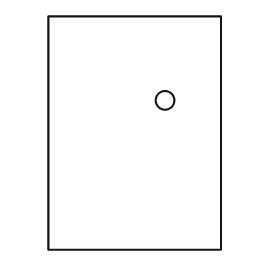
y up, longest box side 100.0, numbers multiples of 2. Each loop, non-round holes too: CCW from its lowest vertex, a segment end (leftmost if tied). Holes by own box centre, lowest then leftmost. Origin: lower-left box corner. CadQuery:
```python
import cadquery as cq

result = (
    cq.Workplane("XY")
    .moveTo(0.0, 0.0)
    .lineTo(74.0, 0.0)
    .lineTo(74.0, 100.0)
    .lineTo(0.0, 100.0)
    .close()
    .moveTo(50.0, 64.0)
    .circle(4.0)
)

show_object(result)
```